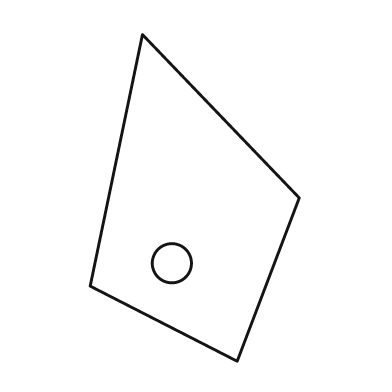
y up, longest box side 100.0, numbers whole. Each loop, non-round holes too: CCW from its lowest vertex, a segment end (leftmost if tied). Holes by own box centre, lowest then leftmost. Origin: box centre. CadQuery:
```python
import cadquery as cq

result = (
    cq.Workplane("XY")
    .moveTo(13.0, -50.0)
    .lineTo(32.0, 0.0)
    .lineTo(-16.0, 50.0)
    .lineTo(-32.0, -27.0)
    .close()
    .moveTo(-7.0, -20.0)
    .circle(6.0)
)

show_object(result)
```